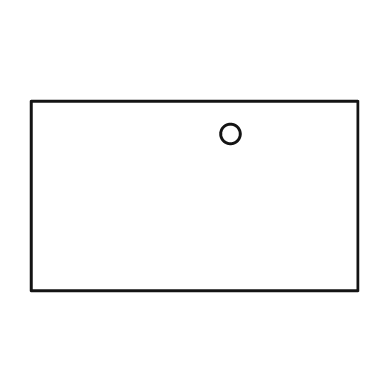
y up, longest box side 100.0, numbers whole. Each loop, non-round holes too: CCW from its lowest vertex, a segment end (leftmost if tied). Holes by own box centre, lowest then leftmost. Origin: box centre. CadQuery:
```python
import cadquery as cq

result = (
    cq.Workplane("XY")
    .moveTo(-50.0, -29.0)
    .lineTo(50.0, -29.0)
    .lineTo(50.0, 29.0)
    .lineTo(-50.0, 29.0)
    .close()
    .moveTo(11.0, 19.0)
    .circle(3.0)
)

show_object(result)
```